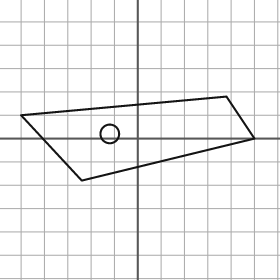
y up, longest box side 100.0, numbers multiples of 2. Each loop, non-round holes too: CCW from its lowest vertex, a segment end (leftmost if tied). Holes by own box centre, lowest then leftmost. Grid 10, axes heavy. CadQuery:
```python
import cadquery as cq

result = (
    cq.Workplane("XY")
    .moveTo(-24.0, -18.0)
    .lineTo(50.0, 0.0)
    .lineTo(38.0, 18.0)
    .lineTo(-50.0, 10.0)
    .close()
    .moveTo(-12.0, 2.0)
    .circle(4.0)
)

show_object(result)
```